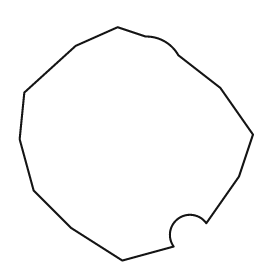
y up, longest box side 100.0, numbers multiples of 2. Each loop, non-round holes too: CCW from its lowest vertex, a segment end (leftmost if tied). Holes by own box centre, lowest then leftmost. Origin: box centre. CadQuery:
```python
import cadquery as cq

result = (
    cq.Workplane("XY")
    .moveTo(-6.0, -50.0)
    .lineTo(16.0, -44.0)
    .threePointArc((18.0, -32.0), (30.0, -34.0))
    .lineTo(44.0, -14.0)
    .lineTo(50.0, 4.0)
    .lineTo(36.0, 24.0)
    .lineTo(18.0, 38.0)
    .threePointArc((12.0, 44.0), (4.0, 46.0))
    .lineTo(-8.0, 50.0)
    .lineTo(-26.0, 42.0)
    .lineTo(-48.0, 22.0)
    .lineTo(-50.0, 2.0)
    .lineTo(-44.0, -20.0)
    .lineTo(-28.0, -36.0)
    .close()
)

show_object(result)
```